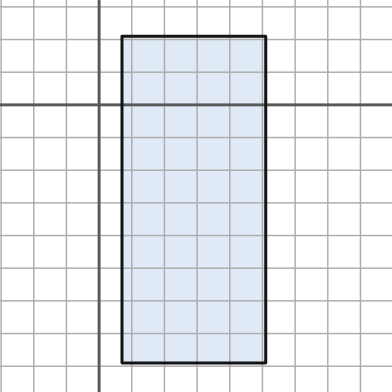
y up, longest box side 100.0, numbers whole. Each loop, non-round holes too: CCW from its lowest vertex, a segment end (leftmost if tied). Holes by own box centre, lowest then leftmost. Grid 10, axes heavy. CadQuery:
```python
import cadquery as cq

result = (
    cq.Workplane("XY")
    .moveTo(7.0, -79.0)
    .lineTo(51.0, -79.0)
    .lineTo(51.0, 21.0)
    .lineTo(7.0, 21.0)
    .close()
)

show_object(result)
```